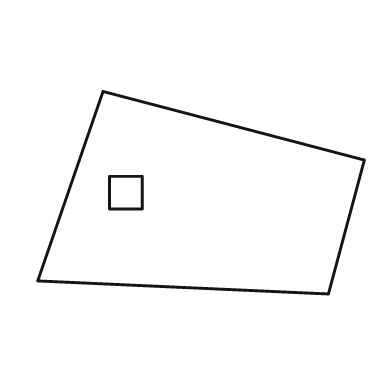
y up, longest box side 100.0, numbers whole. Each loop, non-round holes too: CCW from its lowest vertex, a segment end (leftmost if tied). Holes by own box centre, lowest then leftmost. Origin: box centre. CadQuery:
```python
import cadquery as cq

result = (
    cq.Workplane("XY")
    .moveTo(39.0, -31.0)
    .lineTo(50.0, 10.0)
    .lineTo(-30.0, 31.0)
    .lineTo(-50.0, -27.0)
    .close()
    .moveTo(-28.0, -5.0)
    .lineTo(-18.0, -5.0)
    .lineTo(-18.0, 5.0)
    .lineTo(-28.0, 5.0)
    .close()
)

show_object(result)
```